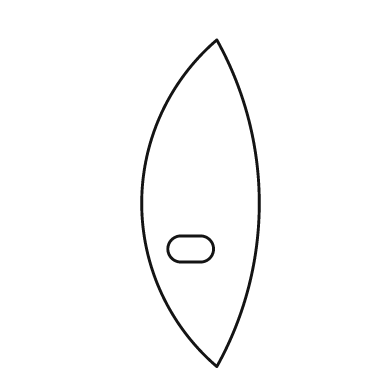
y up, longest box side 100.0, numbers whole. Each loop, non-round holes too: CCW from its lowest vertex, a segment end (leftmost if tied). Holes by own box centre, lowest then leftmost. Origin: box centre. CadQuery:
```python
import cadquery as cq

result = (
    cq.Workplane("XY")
    .moveTo(5.0, -50.0)
    .threePointArc((18.0, 0.0), (5.0, 50.0))
    .threePointArc((-18.0, 0.0), (5.0, -50.0))
    .close()
    .moveTo(-6.0, -18.0)
    .lineTo(0.0, -18.0)
    .threePointArc((4.0, -14.0), (0.0, -10.0))
    .lineTo(-6.0, -10.0)
    .threePointArc((-10.0, -14.0), (-6.0, -18.0))
    .close()
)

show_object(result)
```